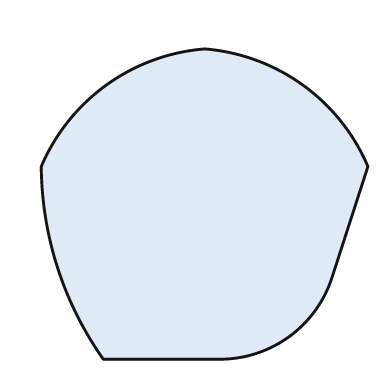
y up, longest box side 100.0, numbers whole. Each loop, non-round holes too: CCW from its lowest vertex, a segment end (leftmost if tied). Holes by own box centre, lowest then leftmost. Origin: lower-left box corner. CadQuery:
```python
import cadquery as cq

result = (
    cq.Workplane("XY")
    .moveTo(19.0, 0.0)
    .lineTo(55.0, 0.0)
    .threePointArc((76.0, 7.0), (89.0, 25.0))
    .lineTo(100.0, 59.0)
    .threePointArc((80.0, 84.0), (50.0, 95.0))
    .threePointArc((20.0, 84.0), (0.0, 59.0))
    .threePointArc((5.0, 28.0), (19.0, 0.0))
    .close()
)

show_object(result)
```